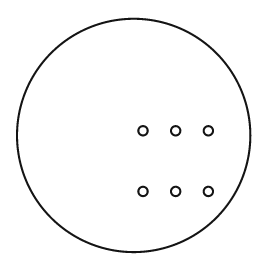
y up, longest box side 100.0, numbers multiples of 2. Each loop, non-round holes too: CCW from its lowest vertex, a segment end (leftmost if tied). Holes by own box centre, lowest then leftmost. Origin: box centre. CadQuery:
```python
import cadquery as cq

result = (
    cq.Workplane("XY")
    .moveTo(0.0, 0.0)
    .circle(50.0)
    .moveTo(4.0, -24.0)
    .circle(2.0)
    .moveTo(18.0, -24.0)
    .circle(2.0)
    .moveTo(32.0, -24.0)
    .circle(2.0)
    .moveTo(4.0, 2.0)
    .circle(2.0)
    .moveTo(18.0, 2.0)
    .circle(2.0)
    .moveTo(32.0, 2.0)
    .circle(2.0)
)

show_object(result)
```